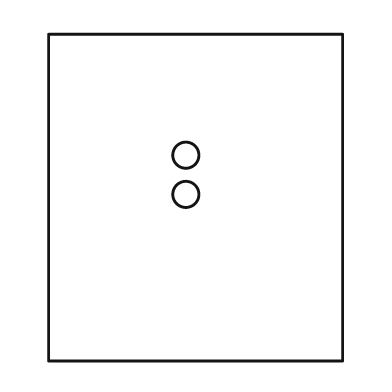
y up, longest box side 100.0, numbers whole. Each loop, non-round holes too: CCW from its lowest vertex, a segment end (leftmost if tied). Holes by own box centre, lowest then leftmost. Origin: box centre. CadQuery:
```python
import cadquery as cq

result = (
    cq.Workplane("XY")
    .moveTo(-45.0, -50.0)
    .lineTo(45.0, -50.0)
    .lineTo(45.0, 50.0)
    .lineTo(-45.0, 50.0)
    .close()
    .moveTo(-3.0, 1.0)
    .circle(4.0)
    .moveTo(-3.0, 13.0)
    .circle(4.0)
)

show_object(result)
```